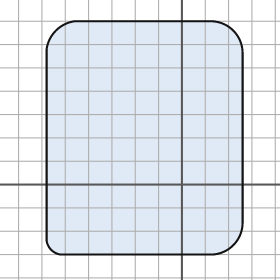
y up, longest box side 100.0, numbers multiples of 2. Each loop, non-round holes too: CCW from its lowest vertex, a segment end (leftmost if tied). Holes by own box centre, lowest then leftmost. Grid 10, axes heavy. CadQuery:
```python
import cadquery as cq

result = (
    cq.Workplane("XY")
    .moveTo(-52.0, -30.0)
    .lineTo(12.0, -30.0)
    .threePointArc((22.0, -26.0), (26.0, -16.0))
    .lineTo(26.0, 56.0)
    .threePointArc((22.0, 66.0), (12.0, 70.0))
    .lineTo(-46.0, 70.0)
    .threePointArc((-54.0, 66.0), (-58.0, 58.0))
    .lineTo(-58.0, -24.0)
    .threePointArc((-56.0, -28.0), (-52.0, -30.0))
    .close()
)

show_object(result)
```